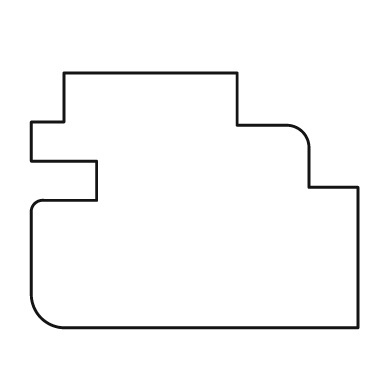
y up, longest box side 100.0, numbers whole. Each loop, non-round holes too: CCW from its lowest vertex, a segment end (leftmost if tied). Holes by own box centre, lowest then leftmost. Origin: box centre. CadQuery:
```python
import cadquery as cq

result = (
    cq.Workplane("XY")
    .moveTo(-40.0, -39.0)
    .lineTo(50.0, -39.0)
    .lineTo(50.0, 4.0)
    .lineTo(35.0, 4.0)
    .lineTo(35.0, 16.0)
    .threePointArc((33.0, 21.0), (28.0, 23.0))
    .lineTo(13.0, 23.0)
    .lineTo(13.0, 39.0)
    .lineTo(-40.0, 39.0)
    .lineTo(-40.0, 24.0)
    .lineTo(-50.0, 24.0)
    .lineTo(-50.0, 12.0)
    .lineTo(-30.0, 12.0)
    .lineTo(-30.0, 0.0)
    .lineTo(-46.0, 0.0)
    .threePointArc((-49.0, -1.0), (-50.0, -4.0))
    .lineTo(-50.0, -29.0)
    .threePointArc((-47.0, -36.0), (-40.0, -39.0))
    .close()
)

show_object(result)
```